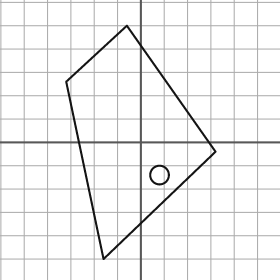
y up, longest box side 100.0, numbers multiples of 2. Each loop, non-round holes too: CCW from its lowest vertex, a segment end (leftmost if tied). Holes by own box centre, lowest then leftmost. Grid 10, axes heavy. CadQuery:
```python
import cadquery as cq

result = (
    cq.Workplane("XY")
    .moveTo(-16.0, -50.0)
    .lineTo(32.0, -4.0)
    .lineTo(-6.0, 50.0)
    .lineTo(-32.0, 26.0)
    .close()
    .moveTo(8.0, -14.0)
    .circle(4.0)
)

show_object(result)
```